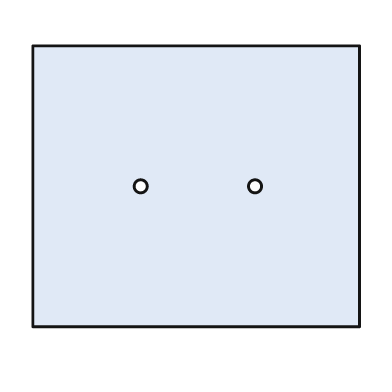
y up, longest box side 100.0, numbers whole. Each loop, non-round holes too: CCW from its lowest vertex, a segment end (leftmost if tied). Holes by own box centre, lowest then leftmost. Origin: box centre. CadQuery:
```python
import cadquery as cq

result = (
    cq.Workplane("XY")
    .moveTo(-50.0, -43.0)
    .lineTo(50.0, -43.0)
    .lineTo(50.0, 43.0)
    .lineTo(-50.0, 43.0)
    .close()
    .moveTo(-17.0, 0.0)
    .circle(2.0)
    .moveTo(18.0, 0.0)
    .circle(2.0)
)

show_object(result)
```